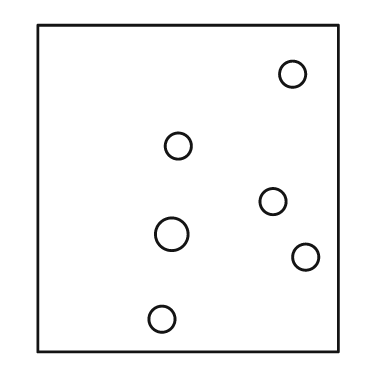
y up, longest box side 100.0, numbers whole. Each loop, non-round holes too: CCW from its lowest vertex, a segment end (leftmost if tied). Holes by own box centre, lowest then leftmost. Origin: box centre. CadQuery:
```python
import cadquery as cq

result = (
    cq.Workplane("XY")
    .moveTo(-46.0, -50.0)
    .lineTo(46.0, -50.0)
    .lineTo(46.0, 50.0)
    .lineTo(-46.0, 50.0)
    .close()
    .moveTo(-8.0, -40.0)
    .circle(4.0)
    .moveTo(36.0, -21.0)
    .circle(4.0)
    .moveTo(-5.0, -14.0)
    .circle(5.0)
    .moveTo(26.0, -4.0)
    .circle(4.0)
    .moveTo(-3.0, 13.0)
    .circle(4.0)
    .moveTo(32.0, 35.0)
    .circle(4.0)
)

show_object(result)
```